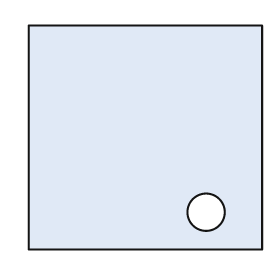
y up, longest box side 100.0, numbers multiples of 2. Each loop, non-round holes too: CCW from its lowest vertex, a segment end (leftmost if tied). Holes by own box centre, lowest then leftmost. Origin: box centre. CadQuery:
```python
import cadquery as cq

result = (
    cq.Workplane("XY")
    .moveTo(-50.0, -48.0)
    .lineTo(50.0, -48.0)
    .lineTo(50.0, 48.0)
    .lineTo(-50.0, 48.0)
    .close()
    .moveTo(26.0, -32.0)
    .circle(8.0)
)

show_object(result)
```